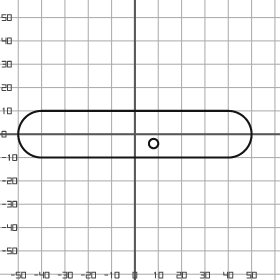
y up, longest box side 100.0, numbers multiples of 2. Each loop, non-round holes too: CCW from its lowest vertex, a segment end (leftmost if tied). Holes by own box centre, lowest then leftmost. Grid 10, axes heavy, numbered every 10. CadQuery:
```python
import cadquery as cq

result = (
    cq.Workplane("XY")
    .moveTo(-40.0, -10.0)
    .lineTo(40.0, -10.0)
    .threePointArc((50.0, 0.0), (40.0, 10.0))
    .lineTo(-40.0, 10.0)
    .threePointArc((-50.0, 0.0), (-40.0, -10.0))
    .close()
    .moveTo(8.0, -4.0)
    .circle(2.0)
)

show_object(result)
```